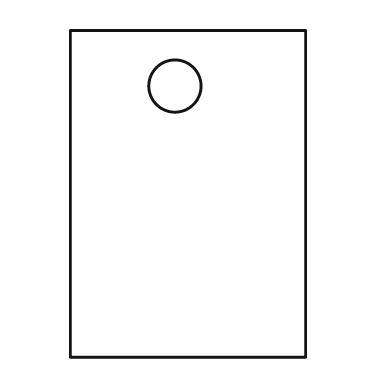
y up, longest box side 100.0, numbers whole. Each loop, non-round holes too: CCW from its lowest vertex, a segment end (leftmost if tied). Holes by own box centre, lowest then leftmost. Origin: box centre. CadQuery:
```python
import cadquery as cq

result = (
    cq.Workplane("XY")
    .moveTo(-36.0, -50.0)
    .lineTo(36.0, -50.0)
    .lineTo(36.0, 50.0)
    .lineTo(-36.0, 50.0)
    .close()
    .moveTo(-4.0, 33.0)
    .circle(8.0)
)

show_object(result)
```